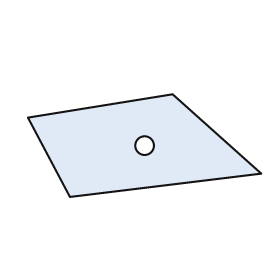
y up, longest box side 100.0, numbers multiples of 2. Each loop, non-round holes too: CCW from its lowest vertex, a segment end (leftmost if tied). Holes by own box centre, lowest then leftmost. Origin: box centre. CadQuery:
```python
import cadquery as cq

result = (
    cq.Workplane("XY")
    .moveTo(-32.0, -22.0)
    .lineTo(50.0, -12.0)
    .lineTo(12.0, 22.0)
    .lineTo(-50.0, 12.0)
    .close()
    .moveTo(0.0, 0.0)
    .circle(4.0)
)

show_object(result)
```